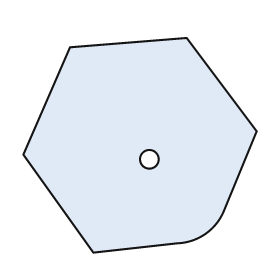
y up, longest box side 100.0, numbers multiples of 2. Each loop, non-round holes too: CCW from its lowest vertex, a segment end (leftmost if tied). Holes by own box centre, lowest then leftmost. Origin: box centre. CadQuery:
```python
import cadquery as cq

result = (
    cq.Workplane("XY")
    .moveTo(-20.0, -46.0)
    .lineTo(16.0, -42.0)
    .threePointArc((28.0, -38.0), (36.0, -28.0))
    .lineTo(50.0, 6.0)
    .lineTo(20.0, 46.0)
    .lineTo(-30.0, 42.0)
    .lineTo(-50.0, -4.0)
    .close()
    .moveTo(4.0, -6.0)
    .circle(4.0)
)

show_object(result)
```